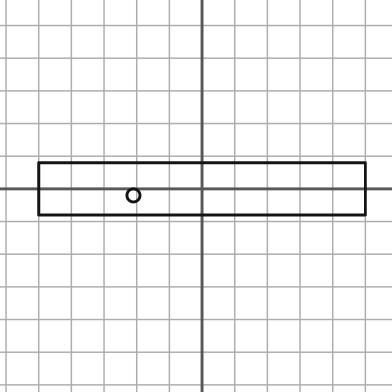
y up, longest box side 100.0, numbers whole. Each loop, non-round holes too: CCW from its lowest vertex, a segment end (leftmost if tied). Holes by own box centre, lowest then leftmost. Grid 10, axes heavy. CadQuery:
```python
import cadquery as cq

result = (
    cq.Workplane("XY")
    .moveTo(-50.0, -8.0)
    .lineTo(50.0, -8.0)
    .lineTo(50.0, 8.0)
    .lineTo(-50.0, 8.0)
    .close()
    .moveTo(-21.0, -2.0)
    .circle(2.0)
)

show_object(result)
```